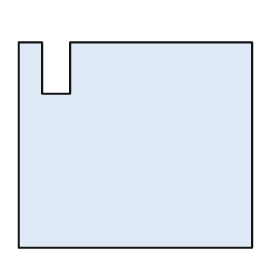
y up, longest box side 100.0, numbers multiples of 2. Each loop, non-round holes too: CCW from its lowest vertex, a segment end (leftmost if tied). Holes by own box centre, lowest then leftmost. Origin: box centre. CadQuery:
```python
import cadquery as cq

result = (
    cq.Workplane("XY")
    .moveTo(-50.0, -44.0)
    .lineTo(50.0, -44.0)
    .lineTo(50.0, 44.0)
    .lineTo(-28.0, 44.0)
    .lineTo(-28.0, 22.0)
    .lineTo(-40.0, 22.0)
    .lineTo(-40.0, 44.0)
    .lineTo(-50.0, 44.0)
    .close()
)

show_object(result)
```